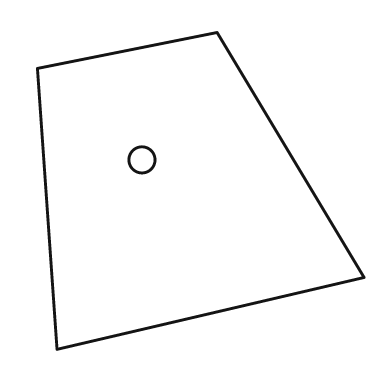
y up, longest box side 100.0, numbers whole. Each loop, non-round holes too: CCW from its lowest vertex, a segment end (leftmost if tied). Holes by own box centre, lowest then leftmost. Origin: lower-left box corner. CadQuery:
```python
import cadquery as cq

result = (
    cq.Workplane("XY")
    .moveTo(6.0, 0.0)
    .lineTo(100.0, 22.0)
    .lineTo(55.0, 97.0)
    .lineTo(0.0, 86.0)
    .close()
    .moveTo(32.0, 58.0)
    .circle(4.0)
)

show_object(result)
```